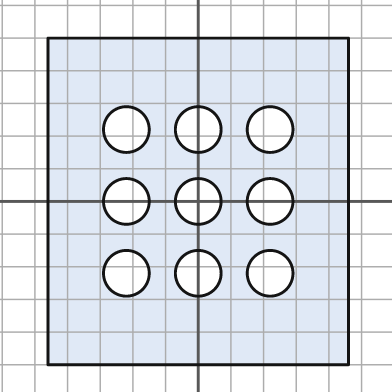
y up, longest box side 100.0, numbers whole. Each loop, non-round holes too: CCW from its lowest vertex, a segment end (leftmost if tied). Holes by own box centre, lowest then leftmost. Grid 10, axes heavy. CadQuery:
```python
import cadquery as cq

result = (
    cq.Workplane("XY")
    .moveTo(-46.0, -50.0)
    .lineTo(46.0, -50.0)
    .lineTo(46.0, 50.0)
    .lineTo(-46.0, 50.0)
    .close()
    .moveTo(-22.0, -22.0)
    .circle(7.0)
    .moveTo(0.0, -22.0)
    .circle(7.0)
    .moveTo(22.0, -22.0)
    .circle(7.0)
    .moveTo(-22.0, 0.0)
    .circle(7.0)
    .moveTo(0.0, 0.0)
    .circle(7.0)
    .moveTo(22.0, 0.0)
    .circle(7.0)
    .moveTo(-22.0, 22.0)
    .circle(7.0)
    .moveTo(0.0, 22.0)
    .circle(7.0)
    .moveTo(22.0, 22.0)
    .circle(7.0)
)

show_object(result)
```